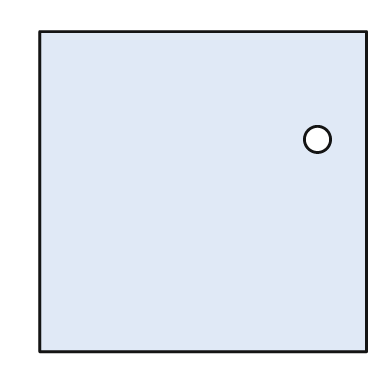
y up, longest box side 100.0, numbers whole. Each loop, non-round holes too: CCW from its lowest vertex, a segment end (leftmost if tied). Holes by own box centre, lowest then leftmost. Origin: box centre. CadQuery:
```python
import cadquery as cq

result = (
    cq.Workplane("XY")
    .moveTo(-50.0, -49.0)
    .lineTo(50.0, -49.0)
    .lineTo(50.0, 49.0)
    .lineTo(-50.0, 49.0)
    .close()
    .moveTo(35.0, 16.0)
    .circle(4.0)
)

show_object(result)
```